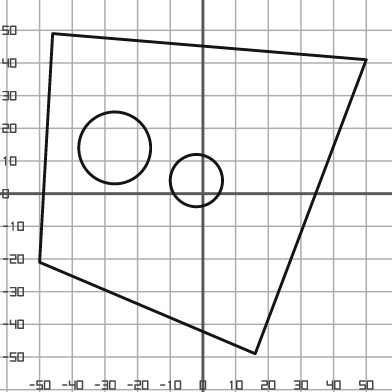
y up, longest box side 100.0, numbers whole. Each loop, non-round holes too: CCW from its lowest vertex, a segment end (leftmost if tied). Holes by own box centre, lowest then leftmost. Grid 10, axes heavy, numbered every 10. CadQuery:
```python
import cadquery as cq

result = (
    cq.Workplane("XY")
    .moveTo(16.0, -49.0)
    .lineTo(50.0, 41.0)
    .lineTo(-46.0, 49.0)
    .lineTo(-50.0, -21.0)
    .close()
    .moveTo(-2.0, 4.0)
    .circle(8.0)
    .moveTo(-27.0, 14.0)
    .circle(11.0)
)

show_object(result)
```